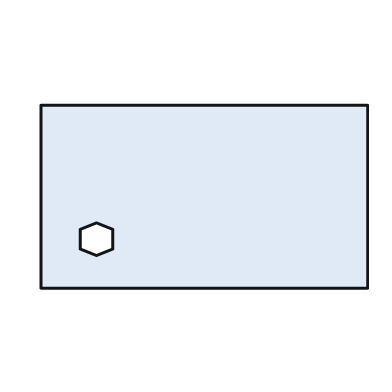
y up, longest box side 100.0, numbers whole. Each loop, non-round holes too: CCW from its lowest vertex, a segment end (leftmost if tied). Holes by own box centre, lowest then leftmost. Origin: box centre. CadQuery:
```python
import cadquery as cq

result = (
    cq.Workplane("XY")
    .moveTo(-50.0, -28.0)
    .lineTo(50.0, -28.0)
    .lineTo(50.0, 28.0)
    .lineTo(-50.0, 28.0)
    .close()
    .moveTo(-33.0, -18.0)
    .lineTo(-28.0, -16.0)
    .lineTo(-28.0, -10.0)
    .lineTo(-33.0, -8.0)
    .lineTo(-38.0, -10.0)
    .lineTo(-38.0, -16.0)
    .close()
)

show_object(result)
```